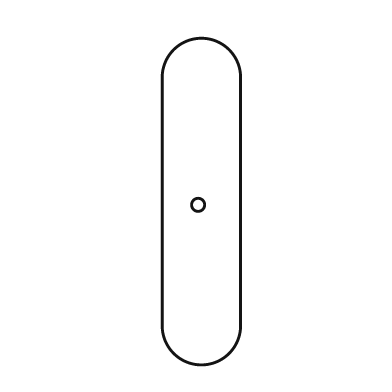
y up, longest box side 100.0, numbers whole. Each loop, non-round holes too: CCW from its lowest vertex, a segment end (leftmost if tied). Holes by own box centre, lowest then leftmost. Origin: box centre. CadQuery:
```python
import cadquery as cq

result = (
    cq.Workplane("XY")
    .moveTo(-12.0, -38.0)
    .threePointArc((0.0, -50.0), (12.0, -38.0))
    .lineTo(12.0, 38.0)
    .threePointArc((0.0, 50.0), (-12.0, 38.0))
    .close()
    .moveTo(-1.0, -1.0)
    .circle(2.0)
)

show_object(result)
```